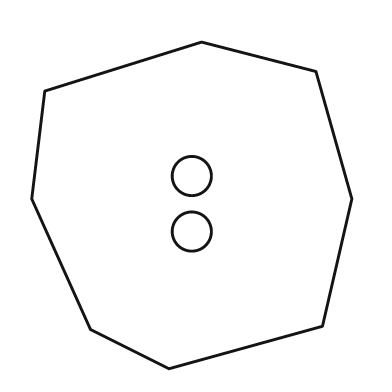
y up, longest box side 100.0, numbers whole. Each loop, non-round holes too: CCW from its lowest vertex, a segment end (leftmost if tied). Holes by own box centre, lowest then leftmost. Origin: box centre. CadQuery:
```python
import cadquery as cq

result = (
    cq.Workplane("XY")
    .moveTo(-7.0, -50.0)
    .lineTo(40.0, -37.0)
    .lineTo(49.0, 2.0)
    .lineTo(38.0, 41.0)
    .lineTo(3.0, 50.0)
    .lineTo(-45.0, 35.0)
    .lineTo(-49.0, 2.0)
    .lineTo(-31.0, -38.0)
    .close()
    .moveTo(0.0, -8.0)
    .circle(6.0)
    .moveTo(0.0, 9.0)
    .circle(6.0)
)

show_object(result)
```